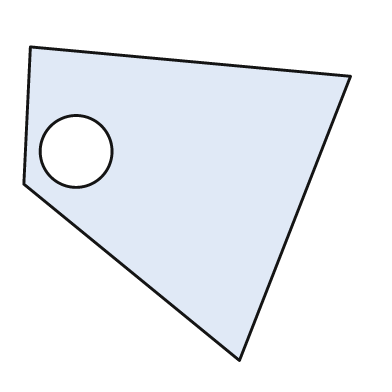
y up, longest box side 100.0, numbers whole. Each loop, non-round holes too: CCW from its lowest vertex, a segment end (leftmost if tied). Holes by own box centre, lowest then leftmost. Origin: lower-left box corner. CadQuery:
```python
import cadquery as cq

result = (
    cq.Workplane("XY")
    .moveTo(66.0, 0.0)
    .lineTo(100.0, 87.0)
    .lineTo(2.0, 96.0)
    .lineTo(0.0, 54.0)
    .close()
    .moveTo(16.0, 64.0)
    .circle(11.0)
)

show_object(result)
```